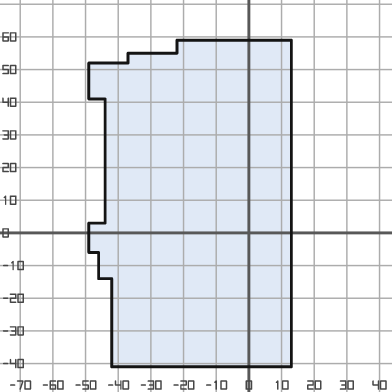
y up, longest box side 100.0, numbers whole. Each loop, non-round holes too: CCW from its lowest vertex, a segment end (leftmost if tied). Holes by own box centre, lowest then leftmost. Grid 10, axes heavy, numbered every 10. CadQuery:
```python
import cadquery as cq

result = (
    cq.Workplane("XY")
    .moveTo(-42.0, -41.0)
    .lineTo(13.0, -41.0)
    .lineTo(13.0, 59.0)
    .lineTo(-22.0, 59.0)
    .lineTo(-22.0, 55.0)
    .lineTo(-37.0, 55.0)
    .lineTo(-37.0, 52.0)
    .lineTo(-49.0, 52.0)
    .lineTo(-49.0, 41.0)
    .lineTo(-44.0, 41.0)
    .lineTo(-44.0, 3.0)
    .lineTo(-49.0, 3.0)
    .lineTo(-49.0, -6.0)
    .lineTo(-46.0, -6.0)
    .lineTo(-46.0, -14.0)
    .lineTo(-42.0, -14.0)
    .close()
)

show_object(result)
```